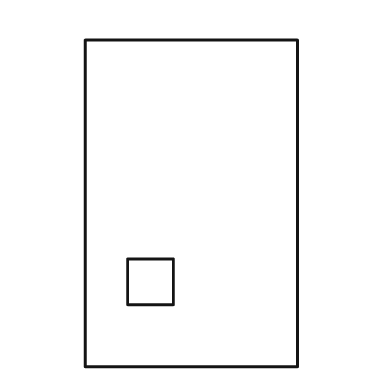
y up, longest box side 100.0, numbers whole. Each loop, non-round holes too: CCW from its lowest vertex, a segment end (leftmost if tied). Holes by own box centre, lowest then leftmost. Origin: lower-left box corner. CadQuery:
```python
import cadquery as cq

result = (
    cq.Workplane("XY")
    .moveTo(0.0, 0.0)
    .lineTo(65.0, 0.0)
    .lineTo(65.0, 100.0)
    .lineTo(0.0, 100.0)
    .close()
    .moveTo(13.0, 19.0)
    .lineTo(27.0, 19.0)
    .lineTo(27.0, 33.0)
    .lineTo(13.0, 33.0)
    .close()
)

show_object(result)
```